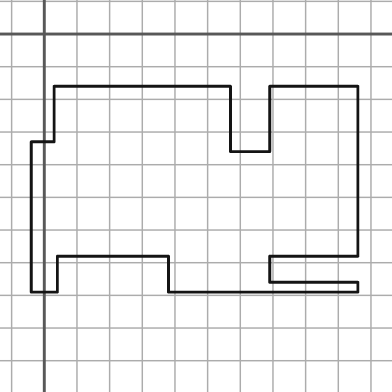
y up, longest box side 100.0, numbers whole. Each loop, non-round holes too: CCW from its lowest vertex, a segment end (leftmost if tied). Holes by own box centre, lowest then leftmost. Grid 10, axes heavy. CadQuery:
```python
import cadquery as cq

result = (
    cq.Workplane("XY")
    .moveTo(-4.0, -79.0)
    .lineTo(4.0, -79.0)
    .lineTo(4.0, -68.0)
    .lineTo(38.0, -68.0)
    .lineTo(38.0, -79.0)
    .lineTo(96.0, -79.0)
    .lineTo(96.0, -76.0)
    .lineTo(69.0, -76.0)
    .lineTo(69.0, -68.0)
    .lineTo(96.0, -68.0)
    .lineTo(96.0, -16.0)
    .lineTo(69.0, -16.0)
    .lineTo(69.0, -36.0)
    .lineTo(57.0, -36.0)
    .lineTo(57.0, -16.0)
    .lineTo(3.0, -16.0)
    .lineTo(3.0, -33.0)
    .lineTo(-4.0, -33.0)
    .close()
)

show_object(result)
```